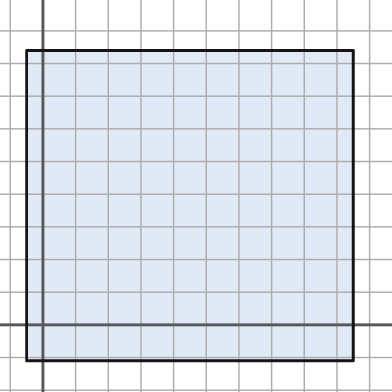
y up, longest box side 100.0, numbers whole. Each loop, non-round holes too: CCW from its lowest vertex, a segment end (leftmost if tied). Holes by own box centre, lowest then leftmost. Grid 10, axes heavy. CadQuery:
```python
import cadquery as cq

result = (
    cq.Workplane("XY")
    .moveTo(-5.0, -11.0)
    .lineTo(95.0, -11.0)
    .lineTo(95.0, 84.0)
    .lineTo(-5.0, 84.0)
    .close()
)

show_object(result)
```